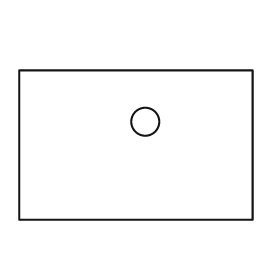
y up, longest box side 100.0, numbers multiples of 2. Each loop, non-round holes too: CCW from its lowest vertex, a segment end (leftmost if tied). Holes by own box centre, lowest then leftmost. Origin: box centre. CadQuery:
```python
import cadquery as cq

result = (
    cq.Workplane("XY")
    .moveTo(-50.0, -32.0)
    .lineTo(50.0, -32.0)
    .lineTo(50.0, 32.0)
    .lineTo(-50.0, 32.0)
    .close()
    .moveTo(4.0, 10.0)
    .circle(6.0)
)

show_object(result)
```